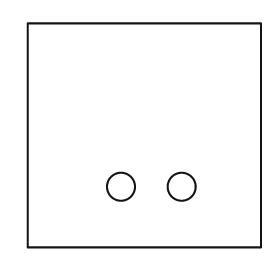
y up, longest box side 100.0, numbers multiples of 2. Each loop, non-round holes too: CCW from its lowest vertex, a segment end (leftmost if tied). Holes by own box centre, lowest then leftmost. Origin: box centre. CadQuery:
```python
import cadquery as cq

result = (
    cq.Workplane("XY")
    .moveTo(-50.0, -48.0)
    .lineTo(50.0, -48.0)
    .lineTo(50.0, 48.0)
    .lineTo(-50.0, 48.0)
    .close()
    .moveTo(-10.0, -22.0)
    .circle(6.0)
    .moveTo(16.0, -22.0)
    .circle(6.0)
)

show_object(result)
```